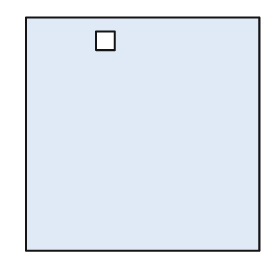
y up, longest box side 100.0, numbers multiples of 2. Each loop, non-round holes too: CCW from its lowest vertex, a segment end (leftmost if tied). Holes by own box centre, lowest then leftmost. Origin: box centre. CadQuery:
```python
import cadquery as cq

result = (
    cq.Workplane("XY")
    .moveTo(-50.0, -50.0)
    .lineTo(50.0, -50.0)
    .lineTo(50.0, 50.0)
    .lineTo(-50.0, 50.0)
    .close()
    .moveTo(-20.0, 36.0)
    .lineTo(-12.0, 36.0)
    .lineTo(-12.0, 44.0)
    .lineTo(-20.0, 44.0)
    .close()
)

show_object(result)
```